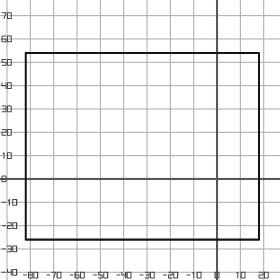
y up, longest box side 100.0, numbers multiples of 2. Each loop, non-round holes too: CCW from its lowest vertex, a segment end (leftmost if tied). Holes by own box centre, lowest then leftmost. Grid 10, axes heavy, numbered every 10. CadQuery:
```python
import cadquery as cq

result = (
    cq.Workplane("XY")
    .moveTo(-82.0, -26.0)
    .lineTo(18.0, -26.0)
    .lineTo(18.0, 54.0)
    .lineTo(-82.0, 54.0)
    .close()
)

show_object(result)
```